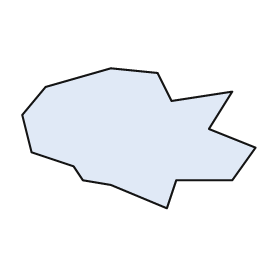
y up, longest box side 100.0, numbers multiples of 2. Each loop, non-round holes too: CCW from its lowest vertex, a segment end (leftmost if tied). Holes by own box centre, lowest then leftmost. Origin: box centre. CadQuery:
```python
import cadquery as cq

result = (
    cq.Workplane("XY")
    .moveTo(12.0, -30.0)
    .lineTo(16.0, -18.0)
    .lineTo(40.0, -18.0)
    .lineTo(50.0, -4.0)
    .lineTo(30.0, 4.0)
    .lineTo(40.0, 20.0)
    .lineTo(14.0, 16.0)
    .lineTo(8.0, 28.0)
    .lineTo(-12.0, 30.0)
    .lineTo(-40.0, 22.0)
    .lineTo(-50.0, 10.0)
    .lineTo(-46.0, -6.0)
    .lineTo(-28.0, -12.0)
    .lineTo(-24.0, -18.0)
    .lineTo(-12.0, -20.0)
    .close()
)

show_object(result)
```